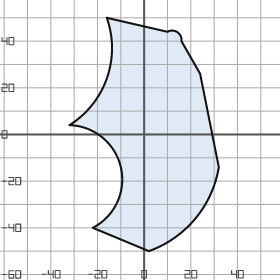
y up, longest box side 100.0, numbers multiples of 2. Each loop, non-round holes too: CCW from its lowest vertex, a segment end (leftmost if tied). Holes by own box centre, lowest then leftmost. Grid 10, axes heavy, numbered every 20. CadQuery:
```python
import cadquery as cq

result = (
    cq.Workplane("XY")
    .moveTo(2.0, -50.0)
    .threePointArc((22.0, -36.0), (32.0, -14.0))
    .lineTo(24.0, 26.0)
    .lineTo(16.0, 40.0)
    .threePointArc((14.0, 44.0), (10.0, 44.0))
    .lineTo(-16.0, 50.0)
    .threePointArc((-16.0, 24.0), (-32.0, 4.0))
    .threePointArc((-10.0, -14.0), (-22.0, -40.0))
    .close()
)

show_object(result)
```